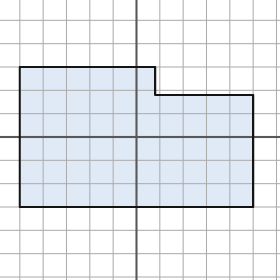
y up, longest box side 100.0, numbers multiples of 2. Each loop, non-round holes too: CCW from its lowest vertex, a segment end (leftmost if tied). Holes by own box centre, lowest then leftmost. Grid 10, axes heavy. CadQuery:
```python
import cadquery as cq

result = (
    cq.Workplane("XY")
    .moveTo(-50.0, -30.0)
    .lineTo(50.0, -30.0)
    .lineTo(50.0, 18.0)
    .lineTo(8.0, 18.0)
    .lineTo(8.0, 30.0)
    .lineTo(-50.0, 30.0)
    .close()
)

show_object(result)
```